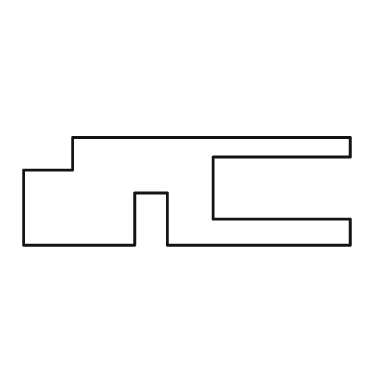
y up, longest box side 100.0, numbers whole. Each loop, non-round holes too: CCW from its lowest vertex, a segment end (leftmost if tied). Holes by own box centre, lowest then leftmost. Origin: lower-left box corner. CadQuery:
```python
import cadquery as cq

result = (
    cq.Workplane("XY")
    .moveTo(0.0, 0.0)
    .lineTo(34.0, 0.0)
    .lineTo(34.0, 16.0)
    .lineTo(44.0, 16.0)
    .lineTo(44.0, 0.0)
    .lineTo(100.0, 0.0)
    .lineTo(100.0, 8.0)
    .lineTo(58.0, 8.0)
    .lineTo(58.0, 27.0)
    .lineTo(100.0, 27.0)
    .lineTo(100.0, 33.0)
    .lineTo(15.0, 33.0)
    .lineTo(15.0, 23.0)
    .lineTo(0.0, 23.0)
    .close()
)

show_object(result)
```